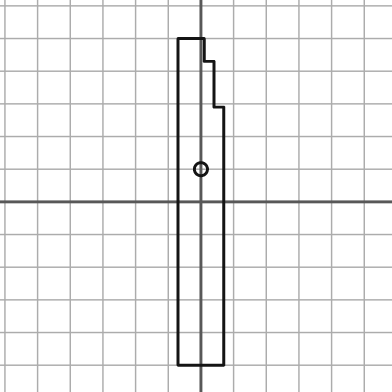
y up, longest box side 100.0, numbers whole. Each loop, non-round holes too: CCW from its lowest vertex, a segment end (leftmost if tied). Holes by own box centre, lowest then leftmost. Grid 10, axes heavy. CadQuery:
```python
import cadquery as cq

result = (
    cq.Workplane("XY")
    .moveTo(-7.0, -50.0)
    .lineTo(7.0, -50.0)
    .lineTo(7.0, 29.0)
    .lineTo(4.0, 29.0)
    .lineTo(4.0, 43.0)
    .lineTo(1.0, 43.0)
    .lineTo(1.0, 50.0)
    .lineTo(-7.0, 50.0)
    .close()
    .moveTo(0.0, 10.0)
    .circle(2.0)
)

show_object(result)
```